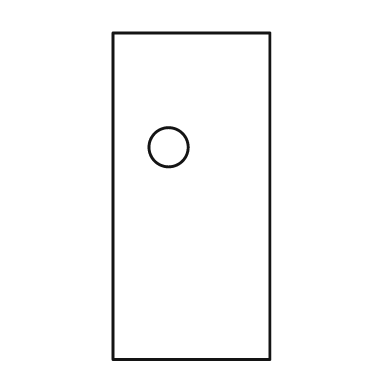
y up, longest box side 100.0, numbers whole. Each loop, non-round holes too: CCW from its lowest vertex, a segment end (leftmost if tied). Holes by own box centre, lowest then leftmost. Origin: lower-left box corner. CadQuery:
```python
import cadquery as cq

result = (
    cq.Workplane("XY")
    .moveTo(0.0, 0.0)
    .lineTo(48.0, 0.0)
    .lineTo(48.0, 100.0)
    .lineTo(0.0, 100.0)
    .close()
    .moveTo(17.0, 65.0)
    .circle(6.0)
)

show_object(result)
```